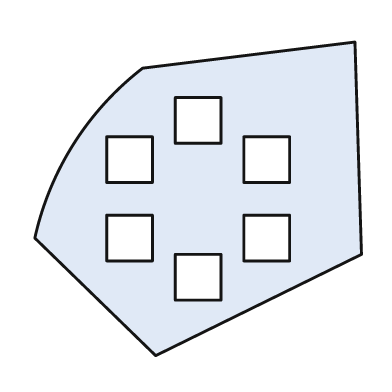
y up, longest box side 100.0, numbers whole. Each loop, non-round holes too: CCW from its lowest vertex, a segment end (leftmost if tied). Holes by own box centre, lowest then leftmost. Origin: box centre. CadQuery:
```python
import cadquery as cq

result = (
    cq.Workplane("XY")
    .moveTo(-13.0, -48.0)
    .lineTo(50.0, -17.0)
    .lineTo(48.0, 48.0)
    .lineTo(-17.0, 40.0)
    .threePointArc((-38.0, 17.0), (-50.0, -12.0))
    .close()
    .moveTo(-7.0, -31.0)
    .lineTo(7.0, -31.0)
    .lineTo(7.0, -17.0)
    .lineTo(-7.0, -17.0)
    .close()
    .moveTo(-28.0, -19.0)
    .lineTo(-14.0, -19.0)
    .lineTo(-14.0, -5.0)
    .lineTo(-28.0, -5.0)
    .close()
    .moveTo(14.0, -19.0)
    .lineTo(28.0, -19.0)
    .lineTo(28.0, -5.0)
    .lineTo(14.0, -5.0)
    .close()
    .moveTo(-28.0, 5.0)
    .lineTo(-14.0, 5.0)
    .lineTo(-14.0, 19.0)
    .lineTo(-28.0, 19.0)
    .close()
    .moveTo(14.0, 5.0)
    .lineTo(28.0, 5.0)
    .lineTo(28.0, 19.0)
    .lineTo(14.0, 19.0)
    .close()
    .moveTo(-7.0, 17.0)
    .lineTo(7.0, 17.0)
    .lineTo(7.0, 31.0)
    .lineTo(-7.0, 31.0)
    .close()
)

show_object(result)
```